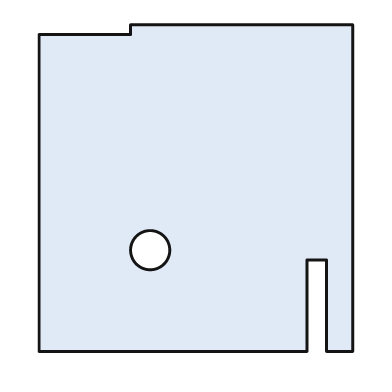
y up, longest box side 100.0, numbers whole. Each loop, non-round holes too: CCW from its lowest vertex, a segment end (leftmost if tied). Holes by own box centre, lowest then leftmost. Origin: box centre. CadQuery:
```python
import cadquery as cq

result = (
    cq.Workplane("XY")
    .moveTo(-48.0, -50.0)
    .lineTo(34.0, -50.0)
    .lineTo(34.0, -22.0)
    .lineTo(40.0, -22.0)
    .lineTo(40.0, -50.0)
    .lineTo(48.0, -50.0)
    .lineTo(48.0, 50.0)
    .lineTo(-20.0, 50.0)
    .lineTo(-20.0, 47.0)
    .lineTo(-48.0, 47.0)
    .close()
    .moveTo(-14.0, -19.0)
    .circle(6.0)
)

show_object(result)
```